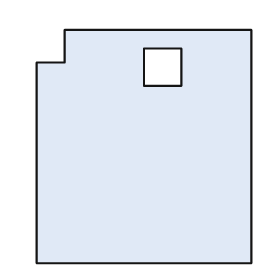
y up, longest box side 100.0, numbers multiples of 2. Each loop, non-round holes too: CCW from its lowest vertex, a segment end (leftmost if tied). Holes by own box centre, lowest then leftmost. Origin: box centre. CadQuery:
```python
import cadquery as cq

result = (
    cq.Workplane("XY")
    .moveTo(-46.0, -50.0)
    .lineTo(46.0, -50.0)
    .lineTo(46.0, 50.0)
    .lineTo(-34.0, 50.0)
    .lineTo(-34.0, 36.0)
    .lineTo(-46.0, 36.0)
    .close()
    .moveTo(0.0, 26.0)
    .lineTo(16.0, 26.0)
    .lineTo(16.0, 42.0)
    .lineTo(0.0, 42.0)
    .close()
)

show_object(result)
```